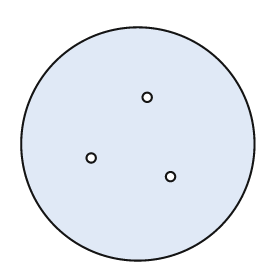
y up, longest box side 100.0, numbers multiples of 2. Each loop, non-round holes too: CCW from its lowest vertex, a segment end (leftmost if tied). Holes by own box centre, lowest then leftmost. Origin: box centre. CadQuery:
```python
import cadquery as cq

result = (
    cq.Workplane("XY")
    .moveTo(0.0, 0.0)
    .circle(50.0)
    .moveTo(14.0, -14.0)
    .circle(2.0)
    .moveTo(-20.0, -6.0)
    .circle(2.0)
    .moveTo(4.0, 20.0)
    .circle(2.0)
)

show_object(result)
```